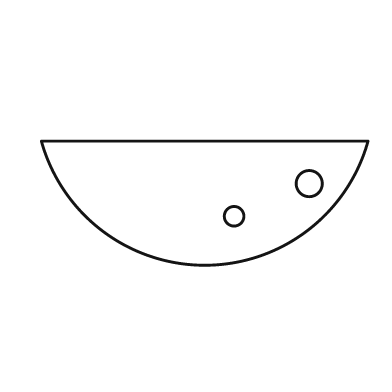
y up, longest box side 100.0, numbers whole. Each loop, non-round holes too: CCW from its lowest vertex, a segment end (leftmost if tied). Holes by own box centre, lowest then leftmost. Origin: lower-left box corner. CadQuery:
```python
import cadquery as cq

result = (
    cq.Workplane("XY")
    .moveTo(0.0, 38.0)
    .threePointArc((50.0, 0.0), (100.0, 38.0))
    .close()
    .moveTo(59.0, 15.0)
    .circle(3.0)
    .moveTo(82.0, 25.0)
    .circle(4.0)
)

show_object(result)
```